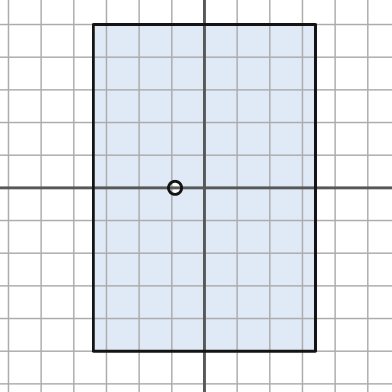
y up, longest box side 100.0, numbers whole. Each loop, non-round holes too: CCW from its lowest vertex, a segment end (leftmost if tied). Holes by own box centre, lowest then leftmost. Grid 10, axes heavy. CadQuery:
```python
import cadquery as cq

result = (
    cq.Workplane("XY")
    .moveTo(-34.0, -50.0)
    .lineTo(34.0, -50.0)
    .lineTo(34.0, 50.0)
    .lineTo(-34.0, 50.0)
    .close()
    .moveTo(-9.0, 0.0)
    .circle(2.0)
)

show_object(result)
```